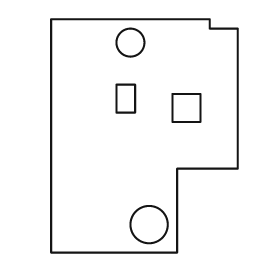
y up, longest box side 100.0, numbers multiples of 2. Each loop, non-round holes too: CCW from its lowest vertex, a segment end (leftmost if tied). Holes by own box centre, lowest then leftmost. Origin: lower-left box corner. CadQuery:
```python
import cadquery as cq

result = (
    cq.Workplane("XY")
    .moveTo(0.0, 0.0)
    .lineTo(54.0, 0.0)
    .lineTo(54.0, 36.0)
    .lineTo(80.0, 36.0)
    .lineTo(80.0, 96.0)
    .lineTo(68.0, 96.0)
    .lineTo(68.0, 100.0)
    .lineTo(0.0, 100.0)
    .close()
    .moveTo(42.0, 12.0)
    .circle(8.0)
    .moveTo(52.0, 56.0)
    .lineTo(64.0, 56.0)
    .lineTo(64.0, 68.0)
    .lineTo(52.0, 68.0)
    .close()
    .moveTo(28.0, 60.0)
    .lineTo(36.0, 60.0)
    .lineTo(36.0, 72.0)
    .lineTo(28.0, 72.0)
    .close()
    .moveTo(34.0, 90.0)
    .circle(6.0)
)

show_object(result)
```